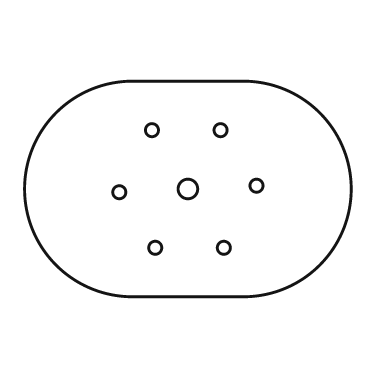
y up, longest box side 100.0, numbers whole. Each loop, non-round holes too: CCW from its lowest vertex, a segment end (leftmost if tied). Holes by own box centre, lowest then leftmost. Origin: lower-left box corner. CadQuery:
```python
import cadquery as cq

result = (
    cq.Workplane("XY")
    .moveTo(33.0, 0.0)
    .lineTo(67.0, 0.0)
    .threePointArc((100.0, 33.0), (67.0, 66.0))
    .lineTo(33.0, 66.0)
    .threePointArc((0.0, 33.0), (33.0, 0.0))
    .close()
    .moveTo(40.0, 15.0)
    .circle(2.0)
    .moveTo(61.0, 15.0)
    .circle(2.0)
    .moveTo(29.0, 32.0)
    .circle(2.0)
    .moveTo(50.0, 33.0)
    .circle(3.0)
    .moveTo(71.0, 34.0)
    .circle(2.0)
    .moveTo(39.0, 51.0)
    .circle(2.0)
    .moveTo(60.0, 51.0)
    .circle(2.0)
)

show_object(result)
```